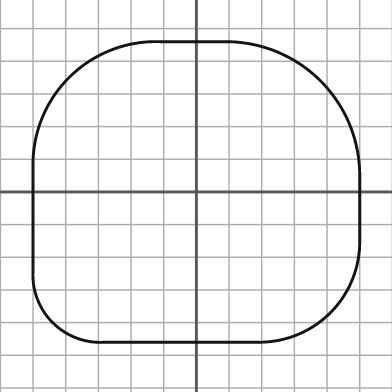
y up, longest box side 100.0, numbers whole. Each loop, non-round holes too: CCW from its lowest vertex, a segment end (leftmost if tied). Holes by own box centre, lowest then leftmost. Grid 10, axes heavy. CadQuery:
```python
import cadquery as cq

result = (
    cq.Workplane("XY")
    .moveTo(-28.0, -46.0)
    .lineTo(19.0, -46.0)
    .threePointArc((41.0, -37.0), (50.0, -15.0))
    .lineTo(50.0, 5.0)
    .threePointArc((38.0, 34.0), (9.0, 46.0))
    .lineTo(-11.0, 46.0)
    .threePointArc((-39.0, 35.0), (-50.0, 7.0))
    .lineTo(-50.0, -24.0)
    .threePointArc((-44.0, -40.0), (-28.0, -46.0))
    .close()
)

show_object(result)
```